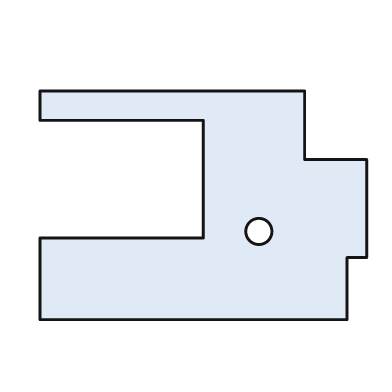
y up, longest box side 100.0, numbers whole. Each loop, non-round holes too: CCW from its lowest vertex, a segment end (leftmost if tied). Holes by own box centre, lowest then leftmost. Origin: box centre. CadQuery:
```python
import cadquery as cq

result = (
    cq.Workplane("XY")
    .moveTo(-50.0, -35.0)
    .lineTo(44.0, -35.0)
    .lineTo(44.0, -16.0)
    .lineTo(50.0, -16.0)
    .lineTo(50.0, 14.0)
    .lineTo(31.0, 14.0)
    .lineTo(31.0, 35.0)
    .lineTo(-50.0, 35.0)
    .lineTo(-50.0, 26.0)
    .lineTo(0.0, 26.0)
    .lineTo(0.0, -10.0)
    .lineTo(-50.0, -10.0)
    .close()
    .moveTo(17.0, -8.0)
    .circle(4.0)
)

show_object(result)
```